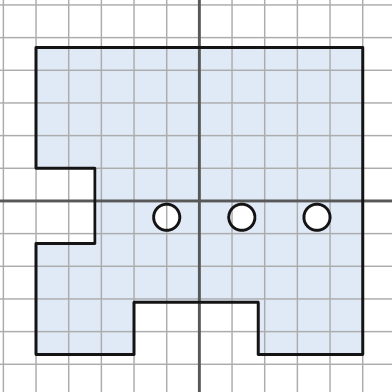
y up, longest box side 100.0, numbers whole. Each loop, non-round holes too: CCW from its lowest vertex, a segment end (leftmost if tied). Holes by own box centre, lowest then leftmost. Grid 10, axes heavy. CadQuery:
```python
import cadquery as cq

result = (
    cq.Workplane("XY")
    .moveTo(-50.0, -47.0)
    .lineTo(-20.0, -47.0)
    .lineTo(-20.0, -31.0)
    .lineTo(18.0, -31.0)
    .lineTo(18.0, -47.0)
    .lineTo(50.0, -47.0)
    .lineTo(50.0, 47.0)
    .lineTo(-50.0, 47.0)
    .lineTo(-50.0, 10.0)
    .lineTo(-32.0, 10.0)
    .lineTo(-32.0, -13.0)
    .lineTo(-50.0, -13.0)
    .close()
    .moveTo(-10.0, -5.0)
    .circle(4.0)
    .moveTo(13.0, -5.0)
    .circle(4.0)
    .moveTo(36.0, -5.0)
    .circle(4.0)
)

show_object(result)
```